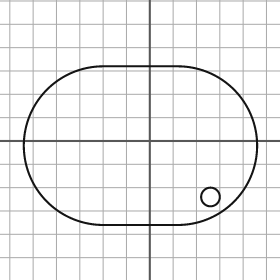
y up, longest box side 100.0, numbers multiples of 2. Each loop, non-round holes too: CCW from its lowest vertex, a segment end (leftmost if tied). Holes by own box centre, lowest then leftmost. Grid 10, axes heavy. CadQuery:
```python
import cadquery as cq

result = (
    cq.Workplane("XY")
    .moveTo(-20.0, -36.0)
    .lineTo(12.0, -36.0)
    .threePointArc((46.0, -2.0), (12.0, 32.0))
    .lineTo(-20.0, 32.0)
    .threePointArc((-54.0, -2.0), (-20.0, -36.0))
    .close()
    .moveTo(26.0, -24.0)
    .circle(4.0)
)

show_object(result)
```